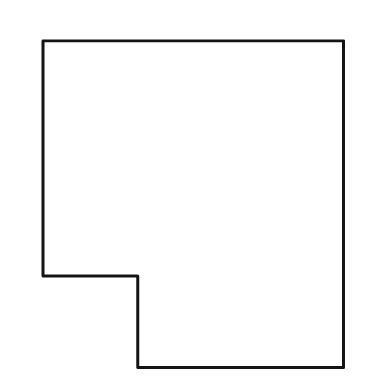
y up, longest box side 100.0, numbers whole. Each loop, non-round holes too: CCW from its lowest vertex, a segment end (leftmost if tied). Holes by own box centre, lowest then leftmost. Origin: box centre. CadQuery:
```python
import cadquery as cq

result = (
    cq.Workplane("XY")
    .moveTo(-17.0, -50.0)
    .lineTo(46.0, -50.0)
    .lineTo(46.0, 50.0)
    .lineTo(-46.0, 50.0)
    .lineTo(-46.0, -22.0)
    .lineTo(-17.0, -22.0)
    .close()
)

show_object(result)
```